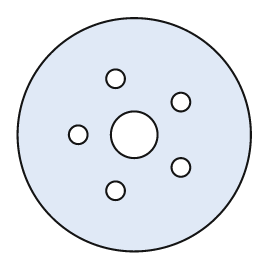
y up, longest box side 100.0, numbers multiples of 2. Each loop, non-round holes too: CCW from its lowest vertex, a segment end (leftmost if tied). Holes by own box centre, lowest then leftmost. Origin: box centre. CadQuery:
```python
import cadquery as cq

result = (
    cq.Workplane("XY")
    .moveTo(0.0, 0.0)
    .circle(50.0)
    .moveTo(-8.0, -24.0)
    .circle(4.0)
    .moveTo(20.0, -14.0)
    .circle(4.0)
    .moveTo(-24.0, 0.0)
    .circle(4.0)
    .moveTo(0.0, 0.0)
    .circle(10.0)
    .moveTo(20.0, 14.0)
    .circle(4.0)
    .moveTo(-8.0, 24.0)
    .circle(4.0)
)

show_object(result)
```